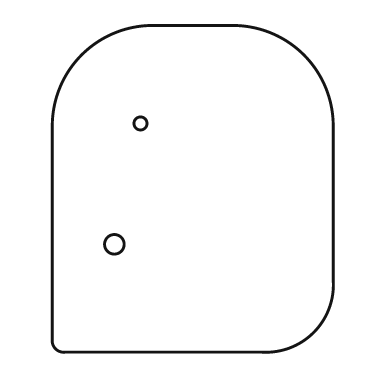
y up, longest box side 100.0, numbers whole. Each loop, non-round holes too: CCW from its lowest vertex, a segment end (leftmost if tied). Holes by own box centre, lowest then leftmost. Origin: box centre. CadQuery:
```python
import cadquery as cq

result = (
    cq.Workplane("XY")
    .moveTo(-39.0, -50.0)
    .lineTo(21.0, -50.0)
    .threePointArc((37.0, -44.0), (43.0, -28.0))
    .lineTo(43.0, 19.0)
    .threePointArc((34.0, 41.0), (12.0, 50.0))
    .lineTo(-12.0, 50.0)
    .threePointArc((-34.0, 41.0), (-43.0, 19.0))
    .lineTo(-43.0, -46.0)
    .threePointArc((-42.0, -49.0), (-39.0, -50.0))
    .close()
    .moveTo(-24.0, -17.0)
    .circle(3.0)
    .moveTo(-16.0, 20.0)
    .circle(2.0)
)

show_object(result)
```